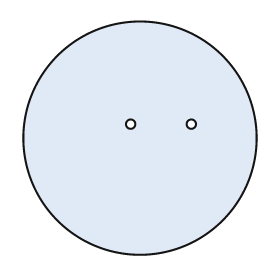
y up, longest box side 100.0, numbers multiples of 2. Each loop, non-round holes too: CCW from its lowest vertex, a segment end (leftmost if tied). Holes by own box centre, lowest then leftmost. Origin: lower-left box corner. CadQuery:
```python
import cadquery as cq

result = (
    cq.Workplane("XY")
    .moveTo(50.0, 50.0)
    .circle(50.0)
    .moveTo(46.0, 56.0)
    .circle(2.0)
    .moveTo(72.0, 56.0)
    .circle(2.0)
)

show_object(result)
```